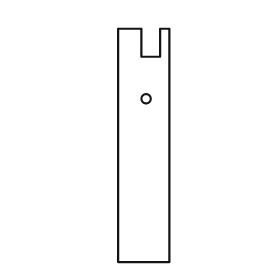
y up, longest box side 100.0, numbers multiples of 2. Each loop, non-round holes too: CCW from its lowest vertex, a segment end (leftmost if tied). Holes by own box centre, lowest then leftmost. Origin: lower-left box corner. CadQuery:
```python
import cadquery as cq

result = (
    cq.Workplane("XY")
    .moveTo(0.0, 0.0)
    .lineTo(22.0, 0.0)
    .lineTo(22.0, 100.0)
    .lineTo(18.0, 100.0)
    .lineTo(18.0, 88.0)
    .lineTo(10.0, 88.0)
    .lineTo(10.0, 100.0)
    .lineTo(0.0, 100.0)
    .close()
    .moveTo(12.0, 70.0)
    .circle(2.0)
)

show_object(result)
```